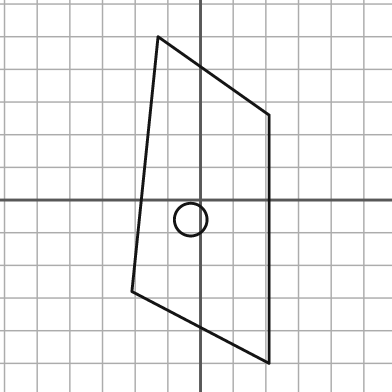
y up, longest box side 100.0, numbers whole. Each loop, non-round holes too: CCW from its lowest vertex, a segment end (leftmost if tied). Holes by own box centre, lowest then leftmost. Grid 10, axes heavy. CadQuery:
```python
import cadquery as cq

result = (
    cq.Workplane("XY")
    .moveTo(21.0, -50.0)
    .lineTo(21.0, 26.0)
    .lineTo(-13.0, 50.0)
    .lineTo(-21.0, -28.0)
    .close()
    .moveTo(-3.0, -6.0)
    .circle(5.0)
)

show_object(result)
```